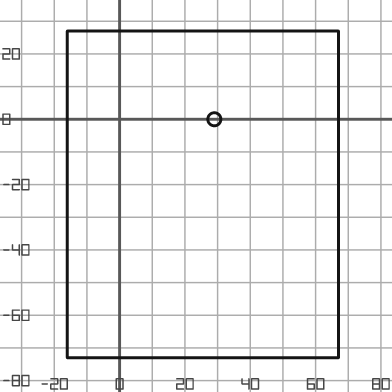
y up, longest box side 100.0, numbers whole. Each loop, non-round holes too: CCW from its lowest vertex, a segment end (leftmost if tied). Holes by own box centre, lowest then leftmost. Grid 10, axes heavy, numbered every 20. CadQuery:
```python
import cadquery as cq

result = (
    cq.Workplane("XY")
    .moveTo(-16.0, -73.0)
    .lineTo(67.0, -73.0)
    .lineTo(67.0, 27.0)
    .lineTo(-16.0, 27.0)
    .close()
    .moveTo(29.0, 0.0)
    .circle(2.0)
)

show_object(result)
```